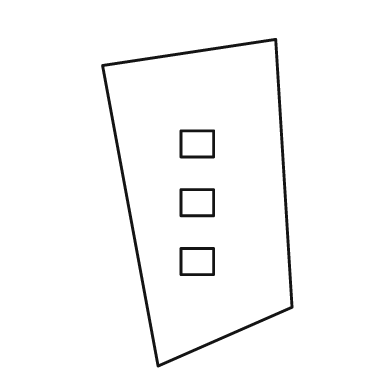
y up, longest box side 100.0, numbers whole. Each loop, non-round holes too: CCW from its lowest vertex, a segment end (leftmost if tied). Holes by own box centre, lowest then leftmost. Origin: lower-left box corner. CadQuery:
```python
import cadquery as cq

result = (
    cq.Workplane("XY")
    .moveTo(17.0, 0.0)
    .lineTo(58.0, 18.0)
    .lineTo(53.0, 100.0)
    .lineTo(0.0, 92.0)
    .close()
    .moveTo(24.0, 28.0)
    .lineTo(34.0, 28.0)
    .lineTo(34.0, 36.0)
    .lineTo(24.0, 36.0)
    .close()
    .moveTo(24.0, 46.0)
    .lineTo(34.0, 46.0)
    .lineTo(34.0, 54.0)
    .lineTo(24.0, 54.0)
    .close()
    .moveTo(24.0, 64.0)
    .lineTo(34.0, 64.0)
    .lineTo(34.0, 72.0)
    .lineTo(24.0, 72.0)
    .close()
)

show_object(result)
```